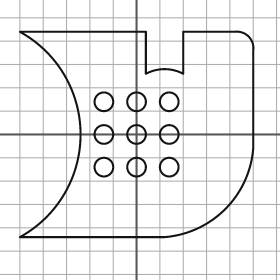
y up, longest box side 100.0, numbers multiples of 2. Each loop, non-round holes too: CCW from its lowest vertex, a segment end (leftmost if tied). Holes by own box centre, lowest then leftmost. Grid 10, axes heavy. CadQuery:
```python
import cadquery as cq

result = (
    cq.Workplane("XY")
    .moveTo(-50.0, -44.0)
    .lineTo(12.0, -44.0)
    .threePointArc((38.0, -32.0), (50.0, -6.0))
    .lineTo(50.0, 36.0)
    .threePointArc((48.0, 42.0), (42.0, 44.0))
    .lineTo(20.0, 44.0)
    .lineTo(20.0, 26.0)
    .threePointArc((12.0, 28.0), (4.0, 26.0))
    .lineTo(4.0, 44.0)
    .lineTo(-50.0, 44.0)
    .threePointArc((-24.0, 0.0), (-50.0, -44.0))
    .close()
    .moveTo(-14.0, -14.0)
    .circle(4.0)
    .moveTo(0.0, -14.0)
    .circle(4.0)
    .moveTo(14.0, -14.0)
    .circle(4.0)
    .moveTo(-14.0, 0.0)
    .circle(4.0)
    .moveTo(0.0, 0.0)
    .circle(4.0)
    .moveTo(14.0, 0.0)
    .circle(4.0)
    .moveTo(-14.0, 14.0)
    .circle(4.0)
    .moveTo(0.0, 14.0)
    .circle(4.0)
    .moveTo(14.0, 14.0)
    .circle(4.0)
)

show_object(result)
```